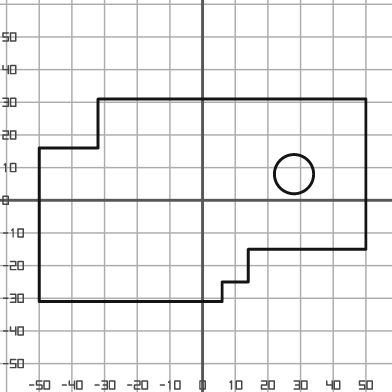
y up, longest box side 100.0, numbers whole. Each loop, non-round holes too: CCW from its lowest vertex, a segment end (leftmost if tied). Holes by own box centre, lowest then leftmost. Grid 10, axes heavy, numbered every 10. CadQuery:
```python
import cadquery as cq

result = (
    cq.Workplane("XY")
    .moveTo(-50.0, -31.0)
    .lineTo(6.0, -31.0)
    .lineTo(6.0, -25.0)
    .lineTo(14.0, -25.0)
    .lineTo(14.0, -15.0)
    .lineTo(50.0, -15.0)
    .lineTo(50.0, 31.0)
    .lineTo(-32.0, 31.0)
    .lineTo(-32.0, 16.0)
    .lineTo(-50.0, 16.0)
    .close()
    .moveTo(28.0, 8.0)
    .circle(6.0)
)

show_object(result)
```